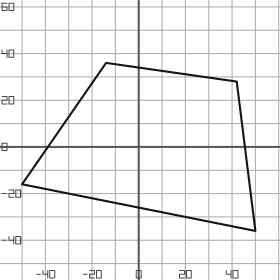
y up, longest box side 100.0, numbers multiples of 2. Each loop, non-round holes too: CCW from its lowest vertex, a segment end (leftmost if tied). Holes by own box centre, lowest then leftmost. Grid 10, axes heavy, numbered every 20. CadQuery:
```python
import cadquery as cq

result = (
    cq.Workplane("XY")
    .moveTo(50.0, -36.0)
    .lineTo(42.0, 28.0)
    .lineTo(-14.0, 36.0)
    .lineTo(-50.0, -16.0)
    .close()
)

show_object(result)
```